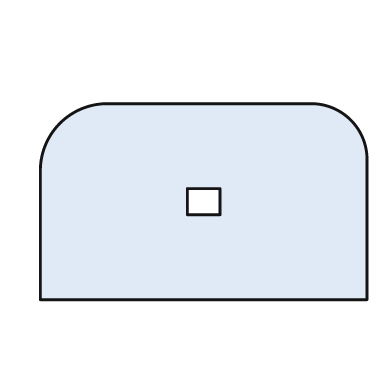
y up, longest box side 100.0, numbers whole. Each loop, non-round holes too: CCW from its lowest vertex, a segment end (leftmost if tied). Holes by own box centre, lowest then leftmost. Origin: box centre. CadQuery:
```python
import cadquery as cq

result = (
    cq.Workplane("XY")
    .moveTo(-50.0, -30.0)
    .lineTo(50.0, -30.0)
    .lineTo(50.0, 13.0)
    .threePointArc((45.0, 25.0), (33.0, 30.0))
    .lineTo(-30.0, 30.0)
    .threePointArc((-44.0, 24.0), (-50.0, 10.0))
    .close()
    .moveTo(-5.0, -4.0)
    .lineTo(5.0, -4.0)
    .lineTo(5.0, 4.0)
    .lineTo(-5.0, 4.0)
    .close()
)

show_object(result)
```